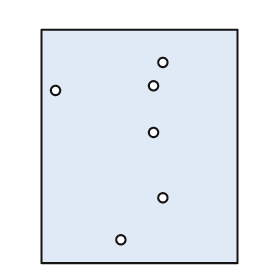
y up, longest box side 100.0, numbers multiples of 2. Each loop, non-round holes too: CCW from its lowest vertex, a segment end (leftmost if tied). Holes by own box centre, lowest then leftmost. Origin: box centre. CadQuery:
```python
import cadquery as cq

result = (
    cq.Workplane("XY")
    .moveTo(-42.0, -50.0)
    .lineTo(42.0, -50.0)
    .lineTo(42.0, 50.0)
    .lineTo(-42.0, 50.0)
    .close()
    .moveTo(-8.0, -40.0)
    .circle(2.0)
    .moveTo(10.0, -22.0)
    .circle(2.0)
    .moveTo(6.0, 6.0)
    .circle(2.0)
    .moveTo(-36.0, 24.0)
    .circle(2.0)
    .moveTo(6.0, 26.0)
    .circle(2.0)
    .moveTo(10.0, 36.0)
    .circle(2.0)
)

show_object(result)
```